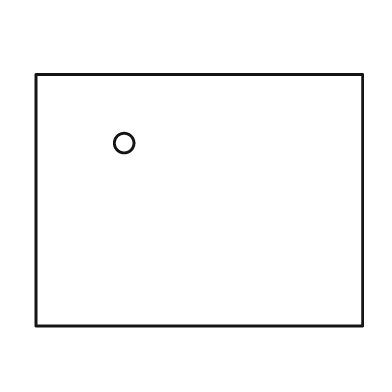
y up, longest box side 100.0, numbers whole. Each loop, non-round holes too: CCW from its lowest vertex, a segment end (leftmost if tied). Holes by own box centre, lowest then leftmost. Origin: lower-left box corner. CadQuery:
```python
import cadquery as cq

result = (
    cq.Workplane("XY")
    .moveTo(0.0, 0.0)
    .lineTo(100.0, 0.0)
    .lineTo(100.0, 77.0)
    .lineTo(0.0, 77.0)
    .close()
    .moveTo(27.0, 56.0)
    .circle(3.0)
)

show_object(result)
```